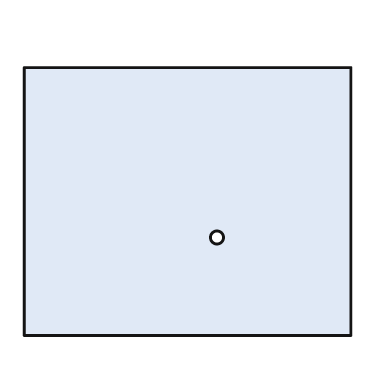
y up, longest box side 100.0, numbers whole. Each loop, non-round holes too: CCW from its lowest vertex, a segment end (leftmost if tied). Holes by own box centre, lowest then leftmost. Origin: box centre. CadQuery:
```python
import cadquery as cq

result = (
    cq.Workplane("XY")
    .moveTo(-50.0, -41.0)
    .lineTo(50.0, -41.0)
    .lineTo(50.0, 41.0)
    .lineTo(-50.0, 41.0)
    .close()
    .moveTo(9.0, -11.0)
    .circle(2.0)
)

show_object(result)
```